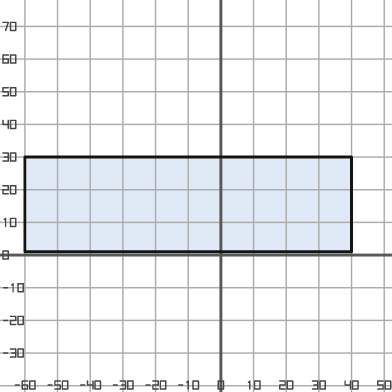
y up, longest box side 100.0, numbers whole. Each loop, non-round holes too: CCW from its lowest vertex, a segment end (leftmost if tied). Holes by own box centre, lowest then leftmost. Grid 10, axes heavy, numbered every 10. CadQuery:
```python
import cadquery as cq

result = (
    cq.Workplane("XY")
    .moveTo(-60.0, 1.0)
    .lineTo(40.0, 1.0)
    .lineTo(40.0, 30.0)
    .lineTo(-60.0, 30.0)
    .close()
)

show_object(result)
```